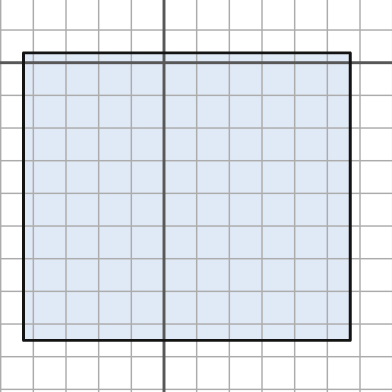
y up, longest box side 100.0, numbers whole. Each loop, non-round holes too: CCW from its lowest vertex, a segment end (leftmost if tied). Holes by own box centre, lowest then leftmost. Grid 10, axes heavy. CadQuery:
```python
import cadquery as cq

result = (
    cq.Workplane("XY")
    .moveTo(-43.0, -85.0)
    .lineTo(57.0, -85.0)
    .lineTo(57.0, 3.0)
    .lineTo(-43.0, 3.0)
    .close()
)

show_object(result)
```